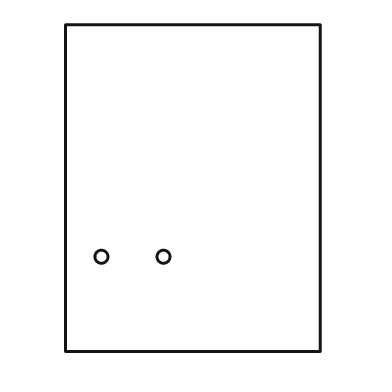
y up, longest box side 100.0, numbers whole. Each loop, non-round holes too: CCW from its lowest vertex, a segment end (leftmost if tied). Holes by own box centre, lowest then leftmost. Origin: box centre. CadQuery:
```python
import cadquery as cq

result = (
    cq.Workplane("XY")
    .moveTo(-39.0, -50.0)
    .lineTo(39.0, -50.0)
    .lineTo(39.0, 50.0)
    .lineTo(-39.0, 50.0)
    .close()
    .moveTo(-28.0, -21.0)
    .circle(2.0)
    .moveTo(-9.0, -21.0)
    .circle(2.0)
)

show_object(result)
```